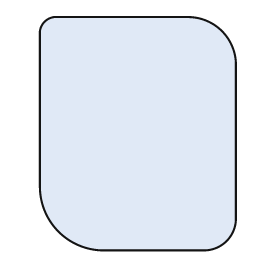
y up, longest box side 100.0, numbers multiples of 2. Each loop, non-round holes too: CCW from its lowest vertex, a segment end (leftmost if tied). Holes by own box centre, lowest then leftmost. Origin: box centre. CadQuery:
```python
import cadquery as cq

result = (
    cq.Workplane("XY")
    .moveTo(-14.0, -50.0)
    .lineTo(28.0, -50.0)
    .threePointArc((38.0, -46.0), (42.0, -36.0))
    .lineTo(42.0, 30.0)
    .threePointArc((36.0, 44.0), (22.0, 50.0))
    .lineTo(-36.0, 50.0)
    .threePointArc((-40.0, 48.0), (-42.0, 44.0))
    .lineTo(-42.0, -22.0)
    .threePointArc((-34.0, -42.0), (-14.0, -50.0))
    .close()
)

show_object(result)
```